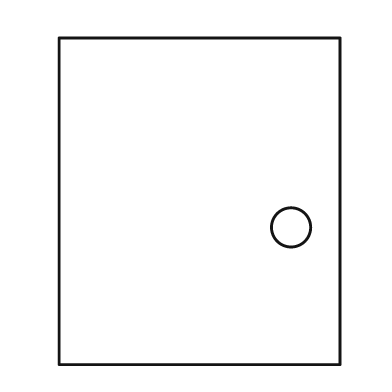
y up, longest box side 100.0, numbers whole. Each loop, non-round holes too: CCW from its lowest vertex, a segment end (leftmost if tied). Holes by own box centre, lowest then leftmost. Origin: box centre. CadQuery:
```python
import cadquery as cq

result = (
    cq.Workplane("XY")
    .moveTo(-43.0, -50.0)
    .lineTo(43.0, -50.0)
    .lineTo(43.0, 50.0)
    .lineTo(-43.0, 50.0)
    .close()
    .moveTo(28.0, -8.0)
    .circle(6.0)
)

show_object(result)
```